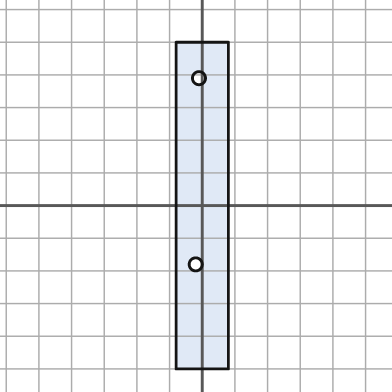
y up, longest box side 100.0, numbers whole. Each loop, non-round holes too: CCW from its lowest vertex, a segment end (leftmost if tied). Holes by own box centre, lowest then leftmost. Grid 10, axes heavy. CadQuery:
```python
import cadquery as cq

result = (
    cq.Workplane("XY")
    .moveTo(-8.0, -50.0)
    .lineTo(8.0, -50.0)
    .lineTo(8.0, 50.0)
    .lineTo(-8.0, 50.0)
    .close()
    .moveTo(-2.0, -18.0)
    .circle(2.0)
    .moveTo(-1.0, 39.0)
    .circle(2.0)
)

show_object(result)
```